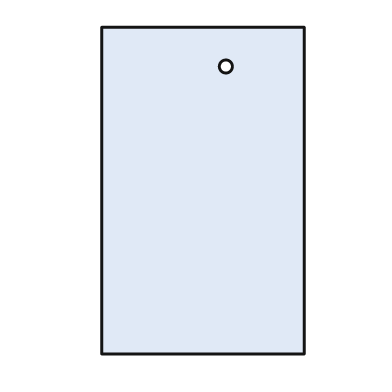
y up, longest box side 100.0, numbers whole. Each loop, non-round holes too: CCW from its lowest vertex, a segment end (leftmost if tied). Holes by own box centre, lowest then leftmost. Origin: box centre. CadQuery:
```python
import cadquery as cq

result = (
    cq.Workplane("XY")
    .moveTo(-31.0, -50.0)
    .lineTo(31.0, -50.0)
    .lineTo(31.0, 50.0)
    .lineTo(-31.0, 50.0)
    .close()
    .moveTo(7.0, 38.0)
    .circle(2.0)
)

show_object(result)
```